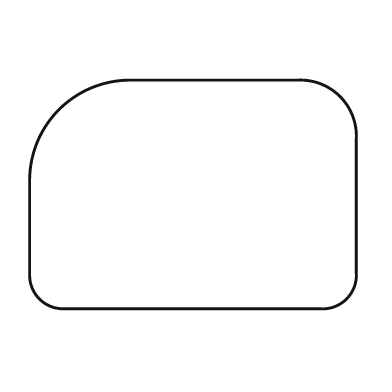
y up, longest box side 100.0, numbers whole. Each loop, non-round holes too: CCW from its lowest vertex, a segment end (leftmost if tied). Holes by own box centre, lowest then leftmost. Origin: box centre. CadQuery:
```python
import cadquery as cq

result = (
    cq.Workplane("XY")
    .moveTo(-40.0, -35.0)
    .lineTo(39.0, -35.0)
    .threePointArc((47.0, -32.0), (50.0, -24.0))
    .lineTo(50.0, 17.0)
    .threePointArc((45.0, 30.0), (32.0, 35.0))
    .lineTo(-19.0, 35.0)
    .threePointArc((-41.0, 26.0), (-50.0, 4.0))
    .lineTo(-50.0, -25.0)
    .threePointArc((-47.0, -32.0), (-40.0, -35.0))
    .close()
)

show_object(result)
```